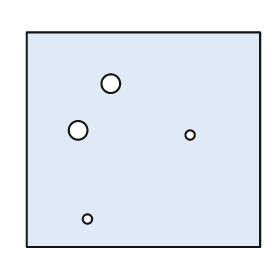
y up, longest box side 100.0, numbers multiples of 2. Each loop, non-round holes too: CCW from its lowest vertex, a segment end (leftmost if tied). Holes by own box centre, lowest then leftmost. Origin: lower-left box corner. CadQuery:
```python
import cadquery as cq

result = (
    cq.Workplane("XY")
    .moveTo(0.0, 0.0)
    .lineTo(100.0, 0.0)
    .lineTo(100.0, 92.0)
    .lineTo(0.0, 92.0)
    .close()
    .moveTo(26.0, 12.0)
    .circle(2.0)
    .moveTo(70.0, 48.0)
    .circle(2.0)
    .moveTo(22.0, 50.0)
    .circle(4.0)
    .moveTo(36.0, 70.0)
    .circle(4.0)
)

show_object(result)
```